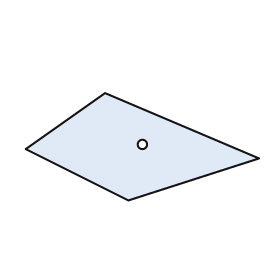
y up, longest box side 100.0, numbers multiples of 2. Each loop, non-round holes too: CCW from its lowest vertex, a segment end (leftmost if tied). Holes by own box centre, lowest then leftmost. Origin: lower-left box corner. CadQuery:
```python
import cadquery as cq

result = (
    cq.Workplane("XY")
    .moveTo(44.0, 0.0)
    .lineTo(100.0, 18.0)
    .lineTo(34.0, 46.0)
    .lineTo(0.0, 22.0)
    .close()
    .moveTo(50.0, 24.0)
    .circle(2.0)
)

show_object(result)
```